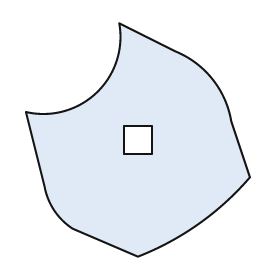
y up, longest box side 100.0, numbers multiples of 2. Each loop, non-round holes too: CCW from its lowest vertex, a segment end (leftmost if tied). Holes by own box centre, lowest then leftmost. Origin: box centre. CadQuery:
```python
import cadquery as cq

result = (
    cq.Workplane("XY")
    .moveTo(0.0, -50.0)
    .threePointArc((26.0, -36.0), (48.0, -16.0))
    .lineTo(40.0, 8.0)
    .threePointArc((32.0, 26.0), (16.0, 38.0))
    .lineTo(-8.0, 50.0)
    .threePointArc((-18.0, 20.0), (-48.0, 12.0))
    .lineTo(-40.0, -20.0)
    .threePointArc((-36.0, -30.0), (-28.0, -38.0))
    .close()
    .moveTo(-6.0, -6.0)
    .lineTo(6.0, -6.0)
    .lineTo(6.0, 6.0)
    .lineTo(-6.0, 6.0)
    .close()
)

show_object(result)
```